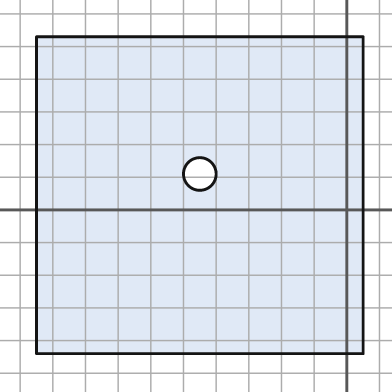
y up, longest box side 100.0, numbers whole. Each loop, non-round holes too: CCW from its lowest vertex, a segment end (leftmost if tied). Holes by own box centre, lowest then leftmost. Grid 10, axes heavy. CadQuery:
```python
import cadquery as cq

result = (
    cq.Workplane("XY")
    .moveTo(-95.0, -44.0)
    .lineTo(5.0, -44.0)
    .lineTo(5.0, 53.0)
    .lineTo(-95.0, 53.0)
    .close()
    .moveTo(-45.0, 11.0)
    .circle(5.0)
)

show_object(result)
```